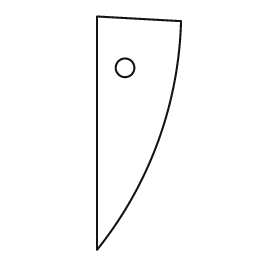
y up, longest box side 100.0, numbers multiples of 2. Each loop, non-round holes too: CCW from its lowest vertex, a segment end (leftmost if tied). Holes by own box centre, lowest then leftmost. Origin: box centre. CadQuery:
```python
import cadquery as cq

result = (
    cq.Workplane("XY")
    .moveTo(-18.0, -50.0)
    .threePointArc((8.0, -4.0), (18.0, 48.0))
    .lineTo(-18.0, 50.0)
    .close()
    .moveTo(-6.0, 28.0)
    .circle(4.0)
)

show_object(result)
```